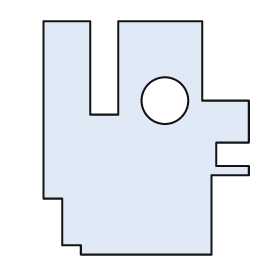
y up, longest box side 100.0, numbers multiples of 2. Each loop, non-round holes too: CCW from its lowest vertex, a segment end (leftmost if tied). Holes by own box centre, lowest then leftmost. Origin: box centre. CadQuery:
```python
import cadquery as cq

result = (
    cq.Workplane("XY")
    .moveTo(-28.0, -50.0)
    .lineTo(28.0, -50.0)
    .lineTo(28.0, -16.0)
    .lineTo(44.0, -16.0)
    .lineTo(44.0, -12.0)
    .lineTo(30.0, -12.0)
    .lineTo(30.0, -2.0)
    .lineTo(44.0, -2.0)
    .lineTo(44.0, 16.0)
    .lineTo(24.0, 16.0)
    .lineTo(24.0, 50.0)
    .lineTo(-12.0, 50.0)
    .lineTo(-12.0, 10.0)
    .lineTo(-24.0, 10.0)
    .lineTo(-24.0, 50.0)
    .lineTo(-44.0, 50.0)
    .lineTo(-44.0, -26.0)
    .lineTo(-36.0, -26.0)
    .lineTo(-36.0, -46.0)
    .lineTo(-28.0, -46.0)
    .close()
    .moveTo(8.0, 16.0)
    .circle(10.0)
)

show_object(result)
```